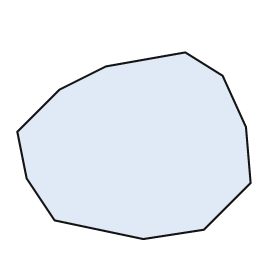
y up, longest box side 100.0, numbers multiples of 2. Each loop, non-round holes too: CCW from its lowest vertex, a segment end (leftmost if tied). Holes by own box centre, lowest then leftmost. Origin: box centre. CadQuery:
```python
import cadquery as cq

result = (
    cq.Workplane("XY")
    .moveTo(4.0, -40.0)
    .lineTo(30.0, -36.0)
    .lineTo(50.0, -16.0)
    .lineTo(48.0, 8.0)
    .lineTo(38.0, 30.0)
    .lineTo(22.0, 40.0)
    .lineTo(-12.0, 34.0)
    .lineTo(-32.0, 24.0)
    .lineTo(-50.0, 6.0)
    .lineTo(-46.0, -14.0)
    .lineTo(-34.0, -32.0)
    .close()
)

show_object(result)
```